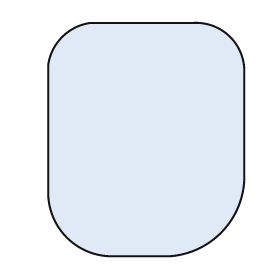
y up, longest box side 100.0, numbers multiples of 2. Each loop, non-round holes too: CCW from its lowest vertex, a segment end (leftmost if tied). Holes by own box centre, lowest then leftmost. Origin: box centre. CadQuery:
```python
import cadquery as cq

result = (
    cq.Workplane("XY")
    .moveTo(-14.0, -50.0)
    .lineTo(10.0, -50.0)
    .threePointArc((32.0, -40.0), (42.0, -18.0))
    .lineTo(42.0, 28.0)
    .threePointArc((36.0, 44.0), (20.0, 50.0))
    .lineTo(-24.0, 50.0)
    .threePointArc((-36.0, 44.0), (-42.0, 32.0))
    .lineTo(-42.0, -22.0)
    .threePointArc((-34.0, -42.0), (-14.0, -50.0))
    .close()
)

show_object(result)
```